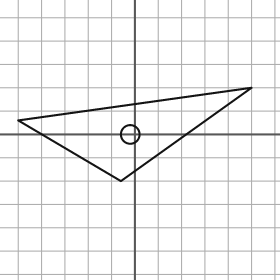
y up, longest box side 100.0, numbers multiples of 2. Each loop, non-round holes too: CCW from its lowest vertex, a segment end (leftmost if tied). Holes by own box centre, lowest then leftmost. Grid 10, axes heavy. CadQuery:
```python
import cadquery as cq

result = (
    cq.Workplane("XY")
    .moveTo(-6.0, -20.0)
    .lineTo(50.0, 20.0)
    .lineTo(-50.0, 6.0)
    .close()
    .moveTo(-2.0, 0.0)
    .circle(4.0)
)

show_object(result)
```